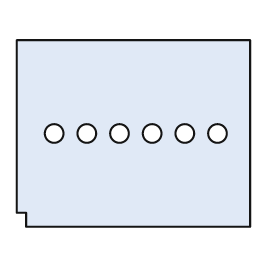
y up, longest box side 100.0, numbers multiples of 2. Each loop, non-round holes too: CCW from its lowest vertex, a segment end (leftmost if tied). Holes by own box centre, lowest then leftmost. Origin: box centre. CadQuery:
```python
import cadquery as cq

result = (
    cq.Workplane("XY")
    .moveTo(-46.0, -40.0)
    .lineTo(50.0, -40.0)
    .lineTo(50.0, 40.0)
    .lineTo(-50.0, 40.0)
    .lineTo(-50.0, -34.0)
    .lineTo(-46.0, -34.0)
    .close()
    .moveTo(-34.0, 0.0)
    .circle(4.0)
    .moveTo(-20.0, 0.0)
    .circle(4.0)
    .moveTo(-6.0, 0.0)
    .circle(4.0)
    .moveTo(8.0, 0.0)
    .circle(4.0)
    .moveTo(22.0, 0.0)
    .circle(4.0)
    .moveTo(36.0, 0.0)
    .circle(4.0)
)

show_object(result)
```